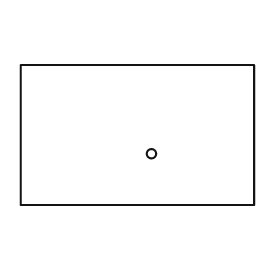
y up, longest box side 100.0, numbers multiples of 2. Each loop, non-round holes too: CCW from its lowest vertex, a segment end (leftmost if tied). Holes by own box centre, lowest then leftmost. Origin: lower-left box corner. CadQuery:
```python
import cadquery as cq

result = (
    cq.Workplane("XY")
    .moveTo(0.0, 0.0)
    .lineTo(100.0, 0.0)
    .lineTo(100.0, 60.0)
    .lineTo(0.0, 60.0)
    .close()
    .moveTo(56.0, 22.0)
    .circle(2.0)
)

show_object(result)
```